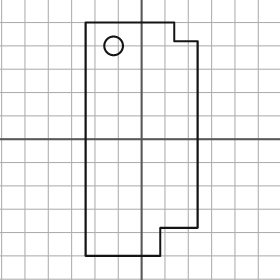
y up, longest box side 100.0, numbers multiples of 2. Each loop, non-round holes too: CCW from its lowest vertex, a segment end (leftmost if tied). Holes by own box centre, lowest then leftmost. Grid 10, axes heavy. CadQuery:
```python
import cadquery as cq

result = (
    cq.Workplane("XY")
    .moveTo(-24.0, -50.0)
    .lineTo(8.0, -50.0)
    .lineTo(8.0, -38.0)
    .lineTo(24.0, -38.0)
    .lineTo(24.0, 42.0)
    .lineTo(14.0, 42.0)
    .lineTo(14.0, 50.0)
    .lineTo(-24.0, 50.0)
    .close()
    .moveTo(-12.0, 40.0)
    .circle(4.0)
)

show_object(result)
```